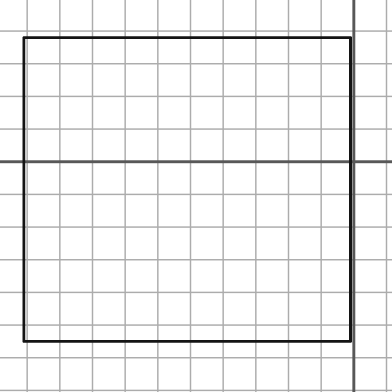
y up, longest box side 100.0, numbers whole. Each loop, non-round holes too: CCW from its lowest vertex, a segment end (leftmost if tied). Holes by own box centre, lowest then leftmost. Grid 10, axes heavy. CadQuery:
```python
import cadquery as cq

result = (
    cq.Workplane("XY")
    .moveTo(-101.0, -55.0)
    .lineTo(-1.0, -55.0)
    .lineTo(-1.0, 38.0)
    .lineTo(-101.0, 38.0)
    .close()
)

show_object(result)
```